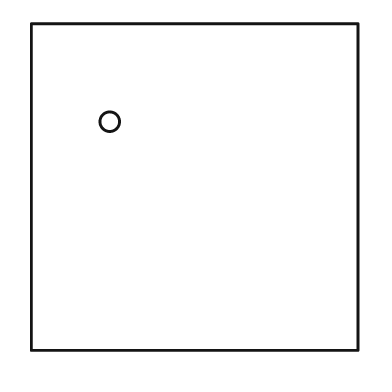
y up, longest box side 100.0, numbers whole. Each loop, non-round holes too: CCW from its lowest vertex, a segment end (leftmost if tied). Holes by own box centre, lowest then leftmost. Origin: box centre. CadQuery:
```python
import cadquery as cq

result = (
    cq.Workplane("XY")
    .moveTo(-50.0, -50.0)
    .lineTo(50.0, -50.0)
    .lineTo(50.0, 50.0)
    .lineTo(-50.0, 50.0)
    .close()
    .moveTo(-26.0, 20.0)
    .circle(3.0)
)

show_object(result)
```